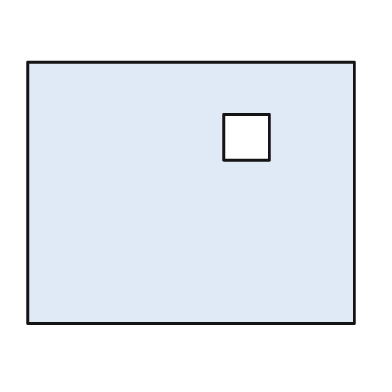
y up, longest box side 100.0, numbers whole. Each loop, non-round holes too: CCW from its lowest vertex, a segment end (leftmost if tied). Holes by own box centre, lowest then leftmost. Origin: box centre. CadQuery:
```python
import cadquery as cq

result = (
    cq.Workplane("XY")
    .moveTo(-50.0, -40.0)
    .lineTo(50.0, -40.0)
    .lineTo(50.0, 40.0)
    .lineTo(-50.0, 40.0)
    .close()
    .moveTo(10.0, 10.0)
    .lineTo(24.0, 10.0)
    .lineTo(24.0, 24.0)
    .lineTo(10.0, 24.0)
    .close()
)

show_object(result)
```